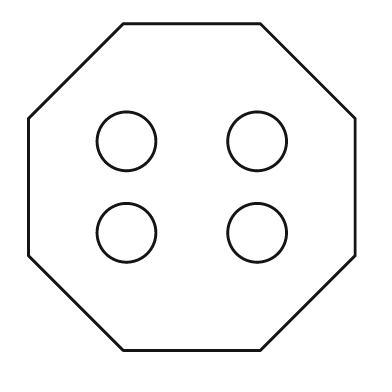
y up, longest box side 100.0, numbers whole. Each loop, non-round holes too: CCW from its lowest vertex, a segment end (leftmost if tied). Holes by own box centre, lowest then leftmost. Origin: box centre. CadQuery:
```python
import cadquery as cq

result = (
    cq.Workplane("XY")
    .moveTo(-21.0, -50.0)
    .lineTo(21.0, -50.0)
    .lineTo(50.0, -21.0)
    .lineTo(50.0, 21.0)
    .lineTo(21.0, 50.0)
    .lineTo(-21.0, 50.0)
    .lineTo(-50.0, 21.0)
    .lineTo(-50.0, -21.0)
    .close()
    .moveTo(-20.0, -14.0)
    .circle(9.0)
    .moveTo(20.0, -14.0)
    .circle(9.0)
    .moveTo(-20.0, 14.0)
    .circle(9.0)
    .moveTo(20.0, 14.0)
    .circle(9.0)
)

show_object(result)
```